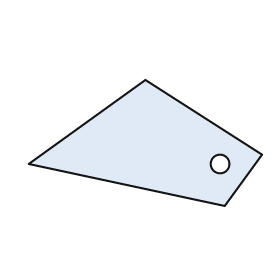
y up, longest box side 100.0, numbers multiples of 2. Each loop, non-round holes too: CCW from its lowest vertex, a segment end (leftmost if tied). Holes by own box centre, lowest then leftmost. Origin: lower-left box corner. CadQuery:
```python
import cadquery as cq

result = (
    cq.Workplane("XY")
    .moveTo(84.0, 0.0)
    .lineTo(100.0, 22.0)
    .lineTo(50.0, 54.0)
    .lineTo(0.0, 18.0)
    .close()
    .moveTo(82.0, 18.0)
    .circle(4.0)
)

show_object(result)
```